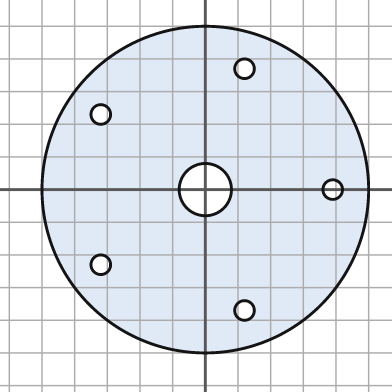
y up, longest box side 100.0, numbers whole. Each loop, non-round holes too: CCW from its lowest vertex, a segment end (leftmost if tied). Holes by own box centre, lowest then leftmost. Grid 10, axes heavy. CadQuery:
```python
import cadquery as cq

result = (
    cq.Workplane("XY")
    .moveTo(0.0, 0.0)
    .circle(50.0)
    .moveTo(12.0, -37.0)
    .circle(3.0)
    .moveTo(-32.0, -23.0)
    .circle(3.0)
    .moveTo(0.0, 0.0)
    .circle(8.0)
    .moveTo(39.0, 0.0)
    .circle(3.0)
    .moveTo(-32.0, 23.0)
    .circle(3.0)
    .moveTo(12.0, 37.0)
    .circle(3.0)
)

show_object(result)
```